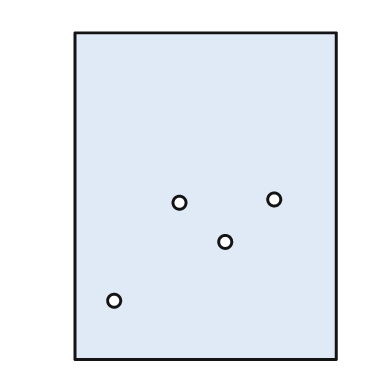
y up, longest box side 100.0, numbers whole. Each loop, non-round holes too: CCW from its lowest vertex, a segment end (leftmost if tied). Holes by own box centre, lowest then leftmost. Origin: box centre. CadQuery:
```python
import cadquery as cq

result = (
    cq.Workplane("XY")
    .moveTo(-40.0, -50.0)
    .lineTo(40.0, -50.0)
    .lineTo(40.0, 50.0)
    .lineTo(-40.0, 50.0)
    .close()
    .moveTo(-28.0, -32.0)
    .circle(2.0)
    .moveTo(6.0, -14.0)
    .circle(2.0)
    .moveTo(-8.0, -2.0)
    .circle(2.0)
    .moveTo(21.0, -1.0)
    .circle(2.0)
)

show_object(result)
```